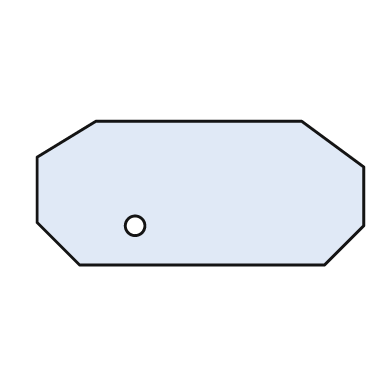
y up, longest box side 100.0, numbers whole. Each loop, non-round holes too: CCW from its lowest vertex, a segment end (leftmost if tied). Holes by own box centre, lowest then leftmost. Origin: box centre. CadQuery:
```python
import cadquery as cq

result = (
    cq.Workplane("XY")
    .moveTo(-37.0, -22.0)
    .lineTo(38.0, -22.0)
    .lineTo(50.0, -10.0)
    .lineTo(50.0, 8.0)
    .lineTo(31.0, 22.0)
    .lineTo(-32.0, 22.0)
    .lineTo(-50.0, 11.0)
    .lineTo(-50.0, -9.0)
    .close()
    .moveTo(-20.0, -10.0)
    .circle(3.0)
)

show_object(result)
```